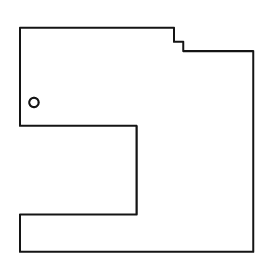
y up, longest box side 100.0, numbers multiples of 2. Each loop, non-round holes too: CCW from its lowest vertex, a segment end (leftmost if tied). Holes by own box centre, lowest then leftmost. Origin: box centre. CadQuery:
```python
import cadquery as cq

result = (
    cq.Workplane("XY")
    .moveTo(-50.0, -48.0)
    .lineTo(50.0, -48.0)
    .lineTo(50.0, 38.0)
    .lineTo(20.0, 38.0)
    .lineTo(20.0, 42.0)
    .lineTo(16.0, 42.0)
    .lineTo(16.0, 48.0)
    .lineTo(-50.0, 48.0)
    .lineTo(-50.0, 6.0)
    .lineTo(0.0, 6.0)
    .lineTo(0.0, -32.0)
    .lineTo(-50.0, -32.0)
    .close()
    .moveTo(-44.0, 16.0)
    .circle(2.0)
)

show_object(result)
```